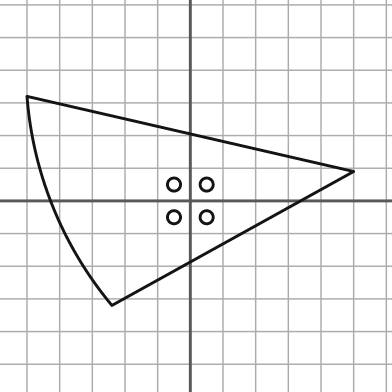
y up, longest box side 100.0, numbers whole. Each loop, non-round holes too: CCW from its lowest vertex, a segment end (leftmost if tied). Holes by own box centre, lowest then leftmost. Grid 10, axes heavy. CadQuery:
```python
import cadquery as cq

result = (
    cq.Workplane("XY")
    .moveTo(-24.0, -32.0)
    .lineTo(50.0, 9.0)
    .lineTo(-50.0, 32.0)
    .threePointArc((-42.0, -2.0), (-24.0, -32.0))
    .close()
    .moveTo(-5.0, -5.0)
    .circle(2.0)
    .moveTo(5.0, -5.0)
    .circle(2.0)
    .moveTo(-5.0, 5.0)
    .circle(2.0)
    .moveTo(5.0, 5.0)
    .circle(2.0)
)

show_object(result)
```